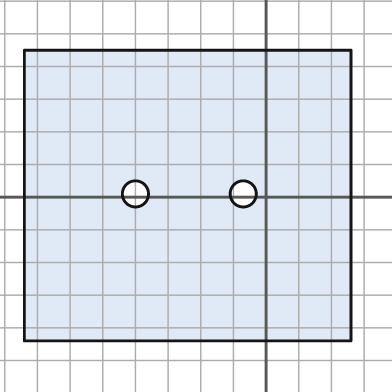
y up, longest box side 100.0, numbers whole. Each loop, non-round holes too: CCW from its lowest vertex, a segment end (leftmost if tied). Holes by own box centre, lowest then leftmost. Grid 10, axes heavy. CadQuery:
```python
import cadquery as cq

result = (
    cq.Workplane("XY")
    .moveTo(-74.0, -44.0)
    .lineTo(26.0, -44.0)
    .lineTo(26.0, 45.0)
    .lineTo(-74.0, 45.0)
    .close()
    .moveTo(-40.0, 1.0)
    .circle(4.0)
    .moveTo(-7.0, 1.0)
    .circle(4.0)
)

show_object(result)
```